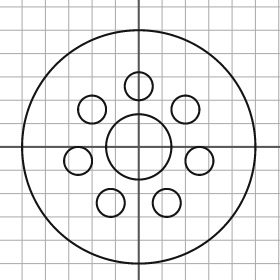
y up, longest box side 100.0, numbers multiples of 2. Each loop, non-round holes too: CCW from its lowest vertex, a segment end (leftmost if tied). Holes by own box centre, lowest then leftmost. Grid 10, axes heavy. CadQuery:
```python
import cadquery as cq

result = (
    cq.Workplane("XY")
    .moveTo(0.0, 0.0)
    .circle(50.0)
    .moveTo(-12.0, -24.0)
    .circle(6.0)
    .moveTo(12.0, -24.0)
    .circle(6.0)
    .moveTo(-26.0, -6.0)
    .circle(6.0)
    .moveTo(26.0, -6.0)
    .circle(6.0)
    .moveTo(0.0, 0.0)
    .circle(14.0)
    .moveTo(-20.0, 16.0)
    .circle(6.0)
    .moveTo(20.0, 16.0)
    .circle(6.0)
    .moveTo(0.0, 26.0)
    .circle(6.0)
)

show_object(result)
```